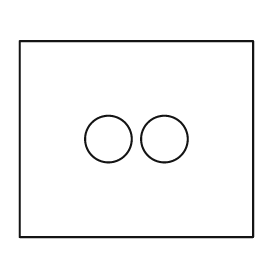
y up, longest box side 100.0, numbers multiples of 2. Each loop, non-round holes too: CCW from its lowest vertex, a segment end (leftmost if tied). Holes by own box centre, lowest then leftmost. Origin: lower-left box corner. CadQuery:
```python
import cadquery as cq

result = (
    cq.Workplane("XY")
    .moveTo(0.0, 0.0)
    .lineTo(100.0, 0.0)
    .lineTo(100.0, 84.0)
    .lineTo(0.0, 84.0)
    .close()
    .moveTo(38.0, 42.0)
    .circle(10.0)
    .moveTo(62.0, 42.0)
    .circle(10.0)
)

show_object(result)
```